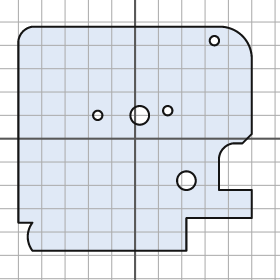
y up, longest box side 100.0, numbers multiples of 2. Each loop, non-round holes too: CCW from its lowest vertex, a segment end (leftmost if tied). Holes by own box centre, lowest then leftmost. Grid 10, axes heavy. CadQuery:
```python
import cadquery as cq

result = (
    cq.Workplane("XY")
    .moveTo(-44.0, -48.0)
    .lineTo(22.0, -48.0)
    .lineTo(22.0, -34.0)
    .lineTo(50.0, -34.0)
    .lineTo(50.0, -22.0)
    .lineTo(36.0, -22.0)
    .lineTo(36.0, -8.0)
    .threePointArc((38.0, -4.0), (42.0, -2.0))
    .lineTo(46.0, -2.0)
    .lineTo(50.0, 2.0)
    .lineTo(50.0, 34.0)
    .threePointArc((46.0, 44.0), (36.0, 48.0))
    .lineTo(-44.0, 48.0)
    .threePointArc((-48.0, 46.0), (-50.0, 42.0))
    .lineTo(-50.0, -36.0)
    .lineTo(-44.0, -36.0)
    .threePointArc((-46.0, -42.0), (-44.0, -48.0))
    .close()
    .moveTo(22.0, -18.0)
    .circle(4.0)
    .moveTo(-16.0, 10.0)
    .circle(2.0)
    .moveTo(2.0, 10.0)
    .circle(4.0)
    .moveTo(14.0, 12.0)
    .circle(2.0)
    .moveTo(34.0, 42.0)
    .circle(2.0)
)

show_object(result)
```